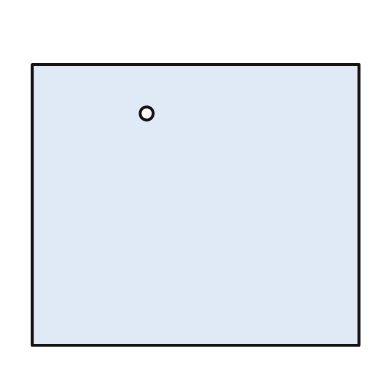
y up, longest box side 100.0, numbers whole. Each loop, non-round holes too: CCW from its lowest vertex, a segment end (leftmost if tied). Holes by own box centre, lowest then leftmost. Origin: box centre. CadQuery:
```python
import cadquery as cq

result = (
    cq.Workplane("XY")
    .moveTo(-50.0, -43.0)
    .lineTo(50.0, -43.0)
    .lineTo(50.0, 43.0)
    .lineTo(-50.0, 43.0)
    .close()
    .moveTo(-15.0, 28.0)
    .circle(2.0)
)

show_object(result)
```